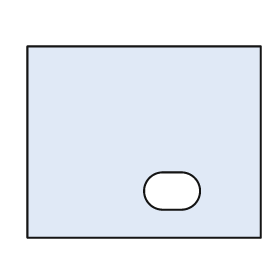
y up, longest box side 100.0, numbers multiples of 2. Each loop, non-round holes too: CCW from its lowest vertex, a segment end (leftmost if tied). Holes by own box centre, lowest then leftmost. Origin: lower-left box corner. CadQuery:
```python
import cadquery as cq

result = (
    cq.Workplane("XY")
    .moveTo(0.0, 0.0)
    .lineTo(100.0, 0.0)
    .lineTo(100.0, 82.0)
    .lineTo(0.0, 82.0)
    .close()
    .moveTo(58.0, 12.0)
    .lineTo(66.0, 12.0)
    .threePointArc((74.0, 20.0), (66.0, 28.0))
    .lineTo(58.0, 28.0)
    .threePointArc((50.0, 20.0), (58.0, 12.0))
    .close()
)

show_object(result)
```